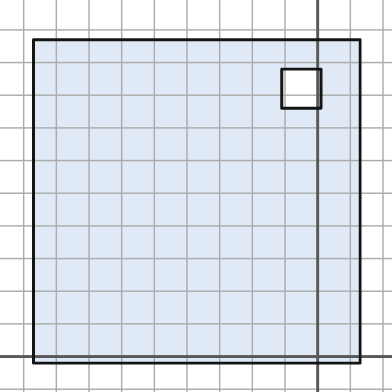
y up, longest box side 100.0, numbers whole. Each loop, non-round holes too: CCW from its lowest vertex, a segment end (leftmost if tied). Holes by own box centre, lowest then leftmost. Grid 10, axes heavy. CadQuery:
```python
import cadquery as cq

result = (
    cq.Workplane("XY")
    .moveTo(-87.0, -2.0)
    .lineTo(13.0, -2.0)
    .lineTo(13.0, 97.0)
    .lineTo(-87.0, 97.0)
    .close()
    .moveTo(-11.0, 76.0)
    .lineTo(1.0, 76.0)
    .lineTo(1.0, 88.0)
    .lineTo(-11.0, 88.0)
    .close()
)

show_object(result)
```